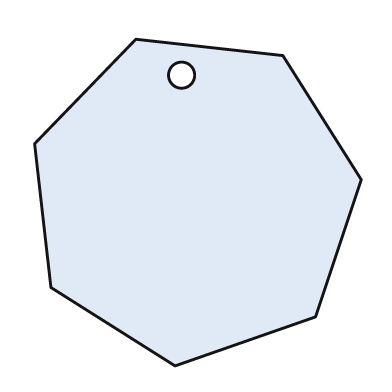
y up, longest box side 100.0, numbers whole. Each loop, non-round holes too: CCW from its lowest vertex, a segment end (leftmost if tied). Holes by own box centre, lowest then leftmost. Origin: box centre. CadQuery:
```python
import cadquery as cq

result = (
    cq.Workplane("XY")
    .moveTo(-7.0, -50.0)
    .lineTo(36.0, -35.0)
    .lineTo(50.0, 7.0)
    .lineTo(26.0, 45.0)
    .lineTo(-19.0, 50.0)
    .lineTo(-50.0, 18.0)
    .lineTo(-45.0, -26.0)
    .close()
    .moveTo(-5.0, 39.0)
    .circle(4.0)
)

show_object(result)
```